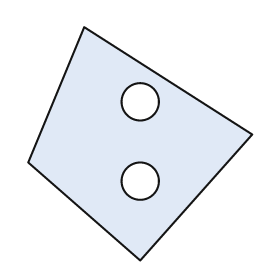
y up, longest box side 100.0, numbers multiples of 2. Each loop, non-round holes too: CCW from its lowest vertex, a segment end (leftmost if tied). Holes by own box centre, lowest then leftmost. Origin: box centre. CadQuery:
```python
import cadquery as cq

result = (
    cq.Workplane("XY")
    .moveTo(0.0, -50.0)
    .lineTo(48.0, 4.0)
    .lineTo(-24.0, 50.0)
    .lineTo(-48.0, -8.0)
    .close()
    .moveTo(0.0, -16.0)
    .circle(8.0)
    .moveTo(0.0, 18.0)
    .circle(8.0)
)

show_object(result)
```